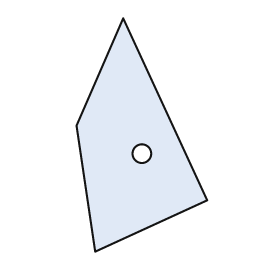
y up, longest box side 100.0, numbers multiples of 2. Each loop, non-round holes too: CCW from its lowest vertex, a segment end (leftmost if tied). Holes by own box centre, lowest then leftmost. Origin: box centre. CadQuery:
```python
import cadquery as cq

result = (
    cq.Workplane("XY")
    .moveTo(-20.0, -50.0)
    .lineTo(28.0, -28.0)
    .lineTo(-8.0, 50.0)
    .lineTo(-28.0, 4.0)
    .close()
    .moveTo(0.0, -8.0)
    .circle(4.0)
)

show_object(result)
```